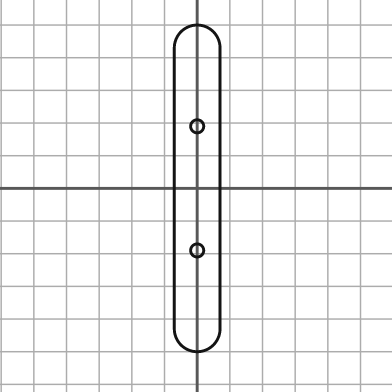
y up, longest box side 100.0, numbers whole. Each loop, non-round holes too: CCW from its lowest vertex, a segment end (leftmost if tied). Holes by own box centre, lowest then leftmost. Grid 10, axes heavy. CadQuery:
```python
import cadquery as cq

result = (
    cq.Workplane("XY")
    .moveTo(-7.0, -43.0)
    .threePointArc((0.0, -50.0), (7.0, -43.0))
    .lineTo(7.0, 43.0)
    .threePointArc((0.0, 50.0), (-7.0, 43.0))
    .close()
    .moveTo(0.0, -19.0)
    .circle(2.0)
    .moveTo(0.0, 19.0)
    .circle(2.0)
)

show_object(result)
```